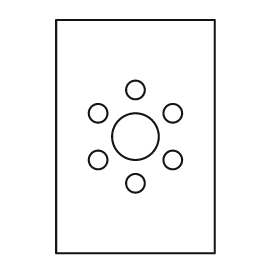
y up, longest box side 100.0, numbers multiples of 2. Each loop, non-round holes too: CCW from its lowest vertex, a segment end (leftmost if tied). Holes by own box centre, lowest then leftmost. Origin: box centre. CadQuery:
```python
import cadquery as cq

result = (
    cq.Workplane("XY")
    .moveTo(-34.0, -50.0)
    .lineTo(34.0, -50.0)
    .lineTo(34.0, 50.0)
    .lineTo(-34.0, 50.0)
    .close()
    .moveTo(0.0, -20.0)
    .circle(4.0)
    .moveTo(-16.0, -10.0)
    .circle(4.0)
    .moveTo(16.0, -10.0)
    .circle(4.0)
    .moveTo(0.0, 0.0)
    .circle(10.0)
    .moveTo(-16.0, 10.0)
    .circle(4.0)
    .moveTo(16.0, 10.0)
    .circle(4.0)
    .moveTo(0.0, 20.0)
    .circle(4.0)
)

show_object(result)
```